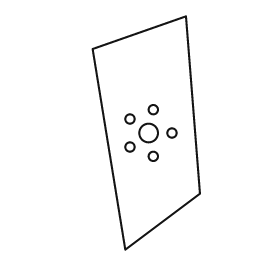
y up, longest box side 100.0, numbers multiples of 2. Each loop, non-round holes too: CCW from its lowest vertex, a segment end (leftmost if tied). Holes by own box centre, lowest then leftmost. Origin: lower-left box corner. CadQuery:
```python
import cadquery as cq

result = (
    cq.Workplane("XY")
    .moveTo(14.0, 0.0)
    .lineTo(46.0, 24.0)
    .lineTo(40.0, 100.0)
    .lineTo(0.0, 86.0)
    .close()
    .moveTo(26.0, 40.0)
    .circle(2.0)
    .moveTo(16.0, 44.0)
    .circle(2.0)
    .moveTo(24.0, 50.0)
    .circle(4.0)
    .moveTo(34.0, 50.0)
    .circle(2.0)
    .moveTo(16.0, 56.0)
    .circle(2.0)
    .moveTo(26.0, 60.0)
    .circle(2.0)
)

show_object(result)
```